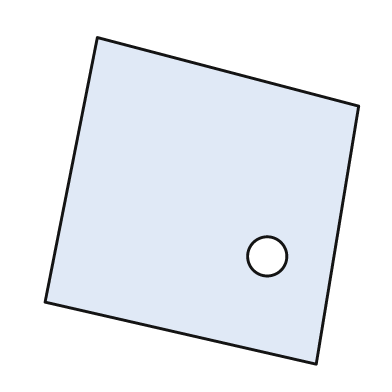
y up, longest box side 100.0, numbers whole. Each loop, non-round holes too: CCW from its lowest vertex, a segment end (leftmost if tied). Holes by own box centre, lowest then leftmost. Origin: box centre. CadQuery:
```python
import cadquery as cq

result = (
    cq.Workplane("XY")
    .moveTo(35.0, -50.0)
    .lineTo(48.0, 29.0)
    .lineTo(-32.0, 50.0)
    .lineTo(-48.0, -31.0)
    .close()
    .moveTo(20.0, -17.0)
    .circle(6.0)
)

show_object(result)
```